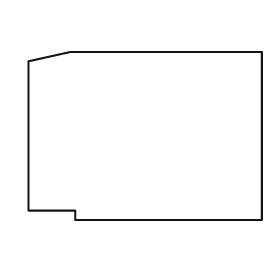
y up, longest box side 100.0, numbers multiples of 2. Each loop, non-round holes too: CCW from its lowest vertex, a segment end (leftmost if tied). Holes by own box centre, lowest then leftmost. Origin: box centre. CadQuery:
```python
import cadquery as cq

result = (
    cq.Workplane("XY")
    .moveTo(-30.0, -36.0)
    .lineTo(50.0, -36.0)
    .lineTo(50.0, 36.0)
    .lineTo(-32.0, 36.0)
    .lineTo(-50.0, 32.0)
    .lineTo(-50.0, -32.0)
    .lineTo(-30.0, -32.0)
    .close()
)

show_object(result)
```